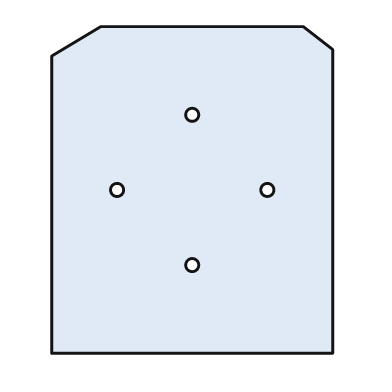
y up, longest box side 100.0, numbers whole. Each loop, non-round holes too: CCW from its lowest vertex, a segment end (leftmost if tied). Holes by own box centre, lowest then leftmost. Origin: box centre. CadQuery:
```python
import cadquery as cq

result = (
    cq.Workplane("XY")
    .moveTo(-43.0, -50.0)
    .lineTo(43.0, -50.0)
    .lineTo(43.0, 43.0)
    .lineTo(34.0, 50.0)
    .lineTo(-28.0, 50.0)
    .lineTo(-43.0, 41.0)
    .close()
    .moveTo(0.0, -23.0)
    .circle(2.0)
    .moveTo(-23.0, 0.0)
    .circle(2.0)
    .moveTo(23.0, 0.0)
    .circle(2.0)
    .moveTo(0.0, 23.0)
    .circle(2.0)
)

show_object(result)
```